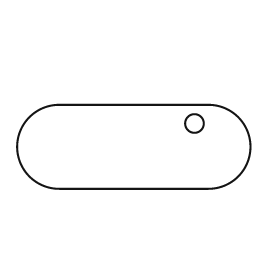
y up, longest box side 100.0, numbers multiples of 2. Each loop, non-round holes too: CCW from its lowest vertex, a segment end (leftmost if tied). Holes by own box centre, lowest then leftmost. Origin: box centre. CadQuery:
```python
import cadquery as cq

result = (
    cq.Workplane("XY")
    .moveTo(-32.0, -18.0)
    .lineTo(32.0, -18.0)
    .threePointArc((50.0, 0.0), (32.0, 18.0))
    .lineTo(-32.0, 18.0)
    .threePointArc((-50.0, 0.0), (-32.0, -18.0))
    .close()
    .moveTo(26.0, 10.0)
    .circle(4.0)
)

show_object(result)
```